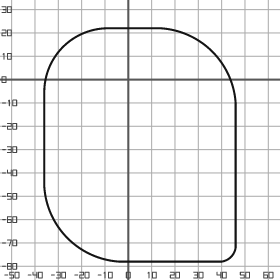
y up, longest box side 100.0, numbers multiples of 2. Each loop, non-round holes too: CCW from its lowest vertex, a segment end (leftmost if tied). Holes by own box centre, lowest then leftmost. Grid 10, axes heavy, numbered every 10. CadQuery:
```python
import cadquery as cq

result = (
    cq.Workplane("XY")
    .moveTo(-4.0, -78.0)
    .lineTo(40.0, -78.0)
    .threePointArc((44.0, -76.0), (46.0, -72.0))
    .lineTo(46.0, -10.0)
    .threePointArc((36.0, 12.0), (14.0, 22.0))
    .lineTo(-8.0, 22.0)
    .threePointArc((-28.0, 14.0), (-36.0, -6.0))
    .lineTo(-36.0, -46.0)
    .threePointArc((-26.0, -68.0), (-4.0, -78.0))
    .close()
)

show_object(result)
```